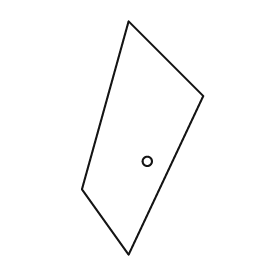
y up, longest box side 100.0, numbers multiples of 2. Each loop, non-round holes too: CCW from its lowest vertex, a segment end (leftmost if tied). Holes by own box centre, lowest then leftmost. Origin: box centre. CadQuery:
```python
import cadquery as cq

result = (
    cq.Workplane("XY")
    .moveTo(-6.0, -50.0)
    .lineTo(26.0, 18.0)
    .lineTo(-6.0, 50.0)
    .lineTo(-26.0, -22.0)
    .close()
    .moveTo(2.0, -10.0)
    .circle(2.0)
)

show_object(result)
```